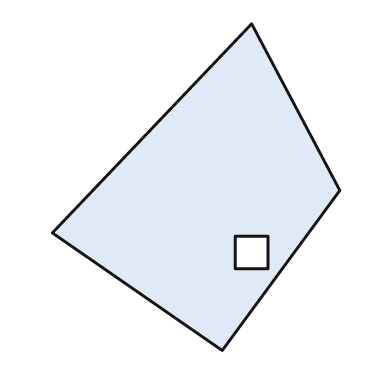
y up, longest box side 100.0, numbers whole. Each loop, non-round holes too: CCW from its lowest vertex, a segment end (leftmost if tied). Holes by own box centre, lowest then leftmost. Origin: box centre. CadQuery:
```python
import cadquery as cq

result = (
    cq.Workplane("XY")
    .moveTo(8.0, -50.0)
    .lineTo(44.0, -1.0)
    .lineTo(17.0, 50.0)
    .lineTo(-44.0, -14.0)
    .close()
    .moveTo(12.0, -25.0)
    .lineTo(22.0, -25.0)
    .lineTo(22.0, -15.0)
    .lineTo(12.0, -15.0)
    .close()
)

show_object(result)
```